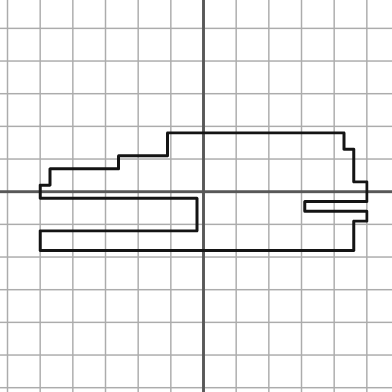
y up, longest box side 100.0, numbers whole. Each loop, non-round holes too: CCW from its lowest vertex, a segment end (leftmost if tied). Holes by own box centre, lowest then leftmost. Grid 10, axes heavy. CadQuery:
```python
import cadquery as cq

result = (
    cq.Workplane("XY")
    .moveTo(-50.0, -18.0)
    .lineTo(46.0, -18.0)
    .lineTo(46.0, -9.0)
    .lineTo(50.0, -9.0)
    .lineTo(50.0, -6.0)
    .lineTo(31.0, -6.0)
    .lineTo(31.0, -3.0)
    .lineTo(50.0, -3.0)
    .lineTo(50.0, 3.0)
    .lineTo(46.0, 3.0)
    .lineTo(46.0, 13.0)
    .lineTo(43.0, 13.0)
    .lineTo(43.0, 18.0)
    .lineTo(-11.0, 18.0)
    .lineTo(-11.0, 11.0)
    .lineTo(-26.0, 11.0)
    .lineTo(-26.0, 7.0)
    .lineTo(-47.0, 7.0)
    .lineTo(-47.0, 2.0)
    .lineTo(-50.0, 2.0)
    .lineTo(-50.0, -2.0)
    .lineTo(-2.0, -2.0)
    .lineTo(-2.0, -12.0)
    .lineTo(-50.0, -12.0)
    .close()
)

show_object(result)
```